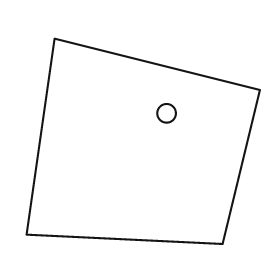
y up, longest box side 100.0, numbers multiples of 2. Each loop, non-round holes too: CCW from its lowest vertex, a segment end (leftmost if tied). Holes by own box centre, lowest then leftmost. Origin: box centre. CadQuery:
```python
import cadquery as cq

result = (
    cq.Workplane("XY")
    .moveTo(34.0, -44.0)
    .lineTo(50.0, 22.0)
    .lineTo(-38.0, 44.0)
    .lineTo(-50.0, -40.0)
    .close()
    .moveTo(10.0, 12.0)
    .circle(4.0)
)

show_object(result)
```